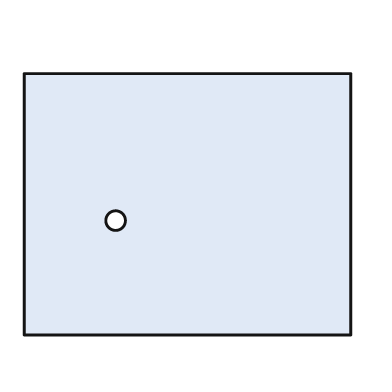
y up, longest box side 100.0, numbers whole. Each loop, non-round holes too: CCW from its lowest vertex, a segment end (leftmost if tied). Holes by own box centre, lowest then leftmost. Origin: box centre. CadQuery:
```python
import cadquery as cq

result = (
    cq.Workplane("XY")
    .moveTo(-50.0, -40.0)
    .lineTo(50.0, -40.0)
    .lineTo(50.0, 40.0)
    .lineTo(-50.0, 40.0)
    .close()
    .moveTo(-22.0, -5.0)
    .circle(3.0)
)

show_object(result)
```